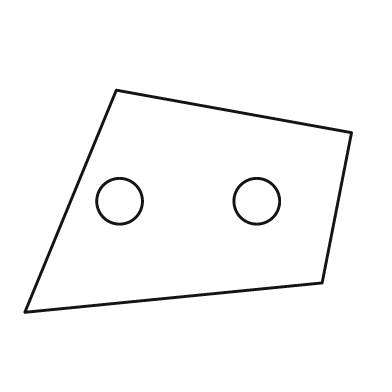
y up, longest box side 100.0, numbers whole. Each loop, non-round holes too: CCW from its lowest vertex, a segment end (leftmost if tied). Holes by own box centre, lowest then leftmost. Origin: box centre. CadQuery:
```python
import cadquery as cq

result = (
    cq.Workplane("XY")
    .moveTo(-50.0, -34.0)
    .lineTo(41.0, -25.0)
    .lineTo(50.0, 21.0)
    .lineTo(-22.0, 34.0)
    .close()
    .moveTo(-21.0, 0.0)
    .circle(7.0)
    .moveTo(21.0, 0.0)
    .circle(7.0)
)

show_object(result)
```